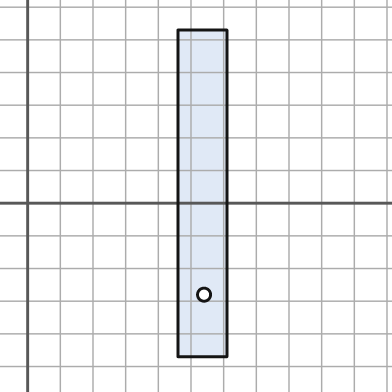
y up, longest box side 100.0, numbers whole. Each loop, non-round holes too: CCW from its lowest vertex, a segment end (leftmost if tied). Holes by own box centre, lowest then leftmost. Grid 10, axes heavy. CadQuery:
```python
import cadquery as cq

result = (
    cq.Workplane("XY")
    .moveTo(46.0, -47.0)
    .lineTo(61.0, -47.0)
    .lineTo(61.0, 53.0)
    .lineTo(46.0, 53.0)
    .close()
    .moveTo(54.0, -28.0)
    .circle(2.0)
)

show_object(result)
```